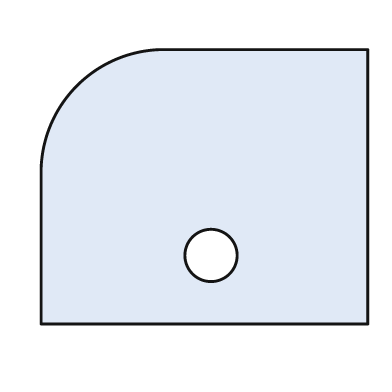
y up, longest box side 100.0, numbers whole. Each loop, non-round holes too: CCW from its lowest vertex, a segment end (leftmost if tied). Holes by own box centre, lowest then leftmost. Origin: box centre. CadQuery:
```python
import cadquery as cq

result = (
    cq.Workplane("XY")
    .moveTo(-50.0, -42.0)
    .lineTo(50.0, -42.0)
    .lineTo(50.0, 42.0)
    .lineTo(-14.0, 42.0)
    .threePointArc((-39.0, 31.0), (-50.0, 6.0))
    .close()
    .moveTo(2.0, -21.0)
    .circle(8.0)
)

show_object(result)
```